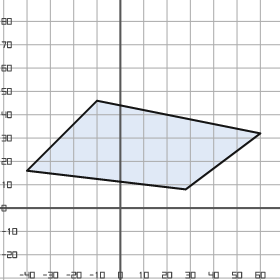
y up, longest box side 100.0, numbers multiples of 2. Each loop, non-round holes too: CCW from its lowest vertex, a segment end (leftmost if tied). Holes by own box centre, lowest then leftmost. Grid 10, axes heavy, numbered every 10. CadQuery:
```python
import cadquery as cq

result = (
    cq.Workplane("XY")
    .moveTo(28.0, 8.0)
    .lineTo(60.0, 32.0)
    .lineTo(-10.0, 46.0)
    .lineTo(-40.0, 16.0)
    .close()
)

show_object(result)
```